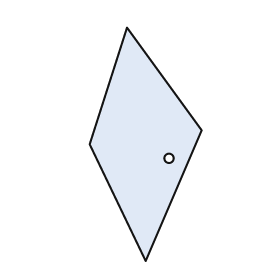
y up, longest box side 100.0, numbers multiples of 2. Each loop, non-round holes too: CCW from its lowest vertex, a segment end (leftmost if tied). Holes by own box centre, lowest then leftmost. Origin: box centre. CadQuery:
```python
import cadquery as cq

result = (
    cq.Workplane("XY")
    .moveTo(0.0, -50.0)
    .lineTo(24.0, 6.0)
    .lineTo(-8.0, 50.0)
    .lineTo(-24.0, 0.0)
    .close()
    .moveTo(10.0, -6.0)
    .circle(2.0)
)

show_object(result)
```